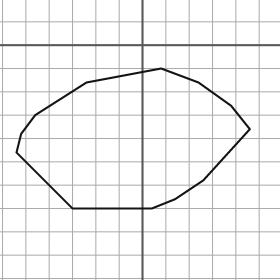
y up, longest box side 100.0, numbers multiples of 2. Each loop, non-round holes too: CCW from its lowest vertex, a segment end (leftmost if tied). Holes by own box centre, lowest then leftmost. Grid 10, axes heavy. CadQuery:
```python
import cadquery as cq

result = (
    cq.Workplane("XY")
    .moveTo(-30.0, -70.0)
    .lineTo(4.0, -70.0)
    .lineTo(14.0, -66.0)
    .lineTo(26.0, -58.0)
    .lineTo(46.0, -36.0)
    .lineTo(38.0, -26.0)
    .lineTo(24.0, -16.0)
    .lineTo(8.0, -10.0)
    .lineTo(-24.0, -16.0)
    .lineTo(-46.0, -30.0)
    .lineTo(-52.0, -38.0)
    .lineTo(-54.0, -46.0)
    .close()
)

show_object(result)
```